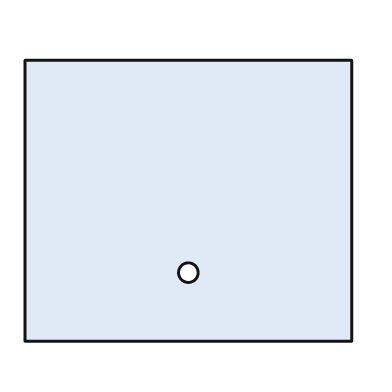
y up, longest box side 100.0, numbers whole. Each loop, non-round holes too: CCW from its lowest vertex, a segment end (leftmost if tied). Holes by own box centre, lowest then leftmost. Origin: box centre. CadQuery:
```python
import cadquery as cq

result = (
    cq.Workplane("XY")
    .moveTo(-50.0, -43.0)
    .lineTo(50.0, -43.0)
    .lineTo(50.0, 43.0)
    .lineTo(-50.0, 43.0)
    .close()
    .moveTo(0.0, -22.0)
    .circle(3.0)
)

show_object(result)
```